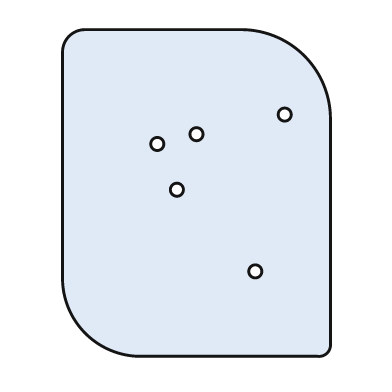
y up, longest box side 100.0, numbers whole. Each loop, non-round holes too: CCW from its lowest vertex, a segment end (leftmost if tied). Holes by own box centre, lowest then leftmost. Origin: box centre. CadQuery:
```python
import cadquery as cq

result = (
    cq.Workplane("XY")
    .moveTo(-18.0, -50.0)
    .lineTo(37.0, -50.0)
    .threePointArc((40.0, -49.0), (41.0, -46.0))
    .lineTo(41.0, 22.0)
    .threePointArc((33.0, 42.0), (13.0, 50.0))
    .lineTo(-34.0, 50.0)
    .threePointArc((-39.0, 48.0), (-41.0, 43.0))
    .lineTo(-41.0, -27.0)
    .threePointArc((-34.0, -43.0), (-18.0, -50.0))
    .close()
    .moveTo(18.0, -24.0)
    .circle(2.0)
    .moveTo(-6.0, 1.0)
    .circle(2.0)
    .moveTo(-12.0, 15.0)
    .circle(2.0)
    .moveTo(0.0, 18.0)
    .circle(2.0)
    .moveTo(27.0, 24.0)
    .circle(2.0)
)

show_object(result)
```